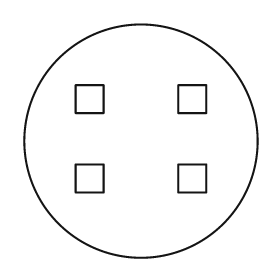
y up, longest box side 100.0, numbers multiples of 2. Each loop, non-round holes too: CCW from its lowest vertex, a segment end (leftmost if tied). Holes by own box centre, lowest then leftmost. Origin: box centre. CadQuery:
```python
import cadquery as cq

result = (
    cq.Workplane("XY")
    .moveTo(0.0, 0.0)
    .circle(50.0)
    .moveTo(-28.0, -22.0)
    .lineTo(-16.0, -22.0)
    .lineTo(-16.0, -10.0)
    .lineTo(-28.0, -10.0)
    .close()
    .moveTo(16.0, -22.0)
    .lineTo(28.0, -22.0)
    .lineTo(28.0, -10.0)
    .lineTo(16.0, -10.0)
    .close()
    .moveTo(-28.0, 12.0)
    .lineTo(-16.0, 12.0)
    .lineTo(-16.0, 24.0)
    .lineTo(-28.0, 24.0)
    .close()
    .moveTo(16.0, 12.0)
    .lineTo(28.0, 12.0)
    .lineTo(28.0, 24.0)
    .lineTo(16.0, 24.0)
    .close()
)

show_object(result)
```